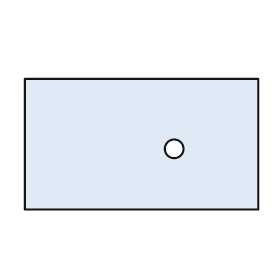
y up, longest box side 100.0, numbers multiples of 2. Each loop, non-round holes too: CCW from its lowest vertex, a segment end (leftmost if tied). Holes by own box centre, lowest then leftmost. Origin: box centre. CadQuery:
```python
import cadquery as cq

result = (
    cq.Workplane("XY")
    .moveTo(-50.0, -28.0)
    .lineTo(50.0, -28.0)
    .lineTo(50.0, 28.0)
    .lineTo(-50.0, 28.0)
    .close()
    .moveTo(14.0, -2.0)
    .circle(4.0)
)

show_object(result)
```